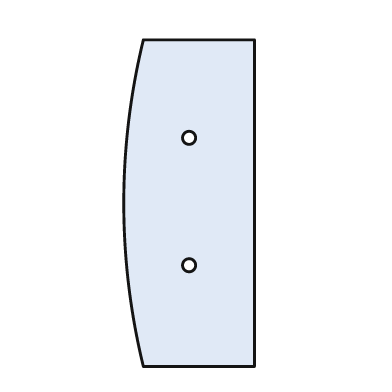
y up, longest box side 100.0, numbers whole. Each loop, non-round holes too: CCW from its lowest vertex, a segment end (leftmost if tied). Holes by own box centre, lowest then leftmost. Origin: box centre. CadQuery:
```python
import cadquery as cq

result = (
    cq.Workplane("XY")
    .moveTo(-14.0, -50.0)
    .lineTo(20.0, -50.0)
    .lineTo(20.0, 50.0)
    .lineTo(-14.0, 50.0)
    .threePointArc((-20.0, 0.0), (-14.0, -50.0))
    .close()
    .moveTo(0.0, -19.0)
    .circle(2.0)
    .moveTo(0.0, 20.0)
    .circle(2.0)
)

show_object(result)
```